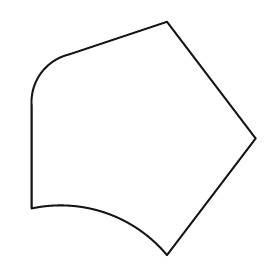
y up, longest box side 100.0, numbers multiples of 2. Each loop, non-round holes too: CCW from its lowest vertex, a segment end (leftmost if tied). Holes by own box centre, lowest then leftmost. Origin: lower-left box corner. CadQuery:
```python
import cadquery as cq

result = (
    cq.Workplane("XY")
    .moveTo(58.0, 0.0)
    .lineTo(96.0, 50.0)
    .lineTo(58.0, 100.0)
    .lineTo(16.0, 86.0)
    .threePointArc((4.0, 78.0), (0.0, 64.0))
    .lineTo(0.0, 20.0)
    .threePointArc((32.0, 18.0), (58.0, 0.0))
    .close()
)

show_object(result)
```